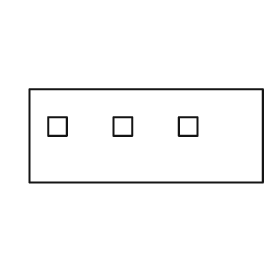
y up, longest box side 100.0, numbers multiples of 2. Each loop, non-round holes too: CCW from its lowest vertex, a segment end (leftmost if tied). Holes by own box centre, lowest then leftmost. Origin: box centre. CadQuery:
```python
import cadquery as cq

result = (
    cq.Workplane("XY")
    .moveTo(-50.0, -20.0)
    .lineTo(50.0, -20.0)
    .lineTo(50.0, 20.0)
    .lineTo(-50.0, 20.0)
    .close()
    .moveTo(-42.0, 0.0)
    .lineTo(-34.0, 0.0)
    .lineTo(-34.0, 8.0)
    .lineTo(-42.0, 8.0)
    .close()
    .moveTo(-14.0, 0.0)
    .lineTo(-6.0, 0.0)
    .lineTo(-6.0, 8.0)
    .lineTo(-14.0, 8.0)
    .close()
    .moveTo(14.0, 0.0)
    .lineTo(22.0, 0.0)
    .lineTo(22.0, 8.0)
    .lineTo(14.0, 8.0)
    .close()
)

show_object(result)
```